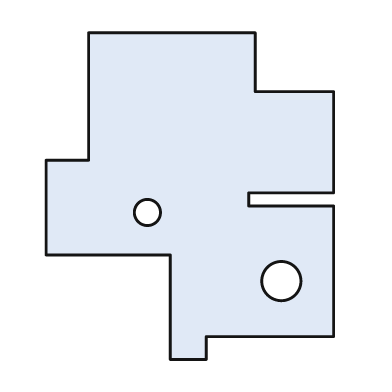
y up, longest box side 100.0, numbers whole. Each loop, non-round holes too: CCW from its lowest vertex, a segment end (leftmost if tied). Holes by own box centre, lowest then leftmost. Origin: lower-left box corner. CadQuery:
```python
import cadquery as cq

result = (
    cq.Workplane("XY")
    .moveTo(38.0, 0.0)
    .lineTo(49.0, 0.0)
    .lineTo(49.0, 7.0)
    .lineTo(88.0, 7.0)
    .lineTo(88.0, 47.0)
    .lineTo(62.0, 47.0)
    .lineTo(62.0, 51.0)
    .lineTo(88.0, 51.0)
    .lineTo(88.0, 82.0)
    .lineTo(64.0, 82.0)
    .lineTo(64.0, 100.0)
    .lineTo(13.0, 100.0)
    .lineTo(13.0, 61.0)
    .lineTo(0.0, 61.0)
    .lineTo(0.0, 32.0)
    .lineTo(38.0, 32.0)
    .close()
    .moveTo(72.0, 24.0)
    .circle(6.0)
    .moveTo(31.0, 45.0)
    .circle(4.0)
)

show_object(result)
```